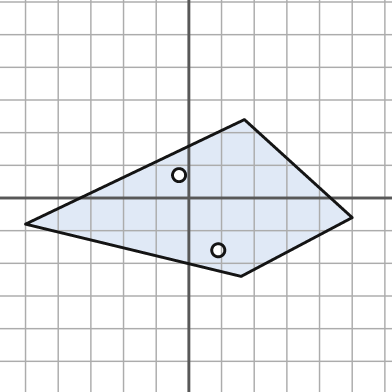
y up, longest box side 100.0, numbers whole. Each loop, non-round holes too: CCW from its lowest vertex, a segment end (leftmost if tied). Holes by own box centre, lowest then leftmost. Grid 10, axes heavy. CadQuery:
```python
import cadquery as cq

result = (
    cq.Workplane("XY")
    .moveTo(16.0, -24.0)
    .lineTo(50.0, -6.0)
    .lineTo(17.0, 24.0)
    .lineTo(-50.0, -8.0)
    .close()
    .moveTo(9.0, -16.0)
    .circle(2.0)
    .moveTo(-3.0, 7.0)
    .circle(2.0)
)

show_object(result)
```